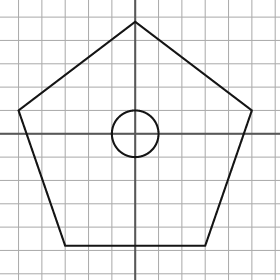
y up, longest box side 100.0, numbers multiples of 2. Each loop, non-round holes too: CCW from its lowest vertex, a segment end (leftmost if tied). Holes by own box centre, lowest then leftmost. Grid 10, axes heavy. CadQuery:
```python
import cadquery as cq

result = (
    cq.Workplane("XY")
    .moveTo(-30.0, -48.0)
    .lineTo(30.0, -48.0)
    .lineTo(50.0, 10.0)
    .lineTo(0.0, 48.0)
    .lineTo(-50.0, 10.0)
    .close()
    .moveTo(0.0, 0.0)
    .circle(10.0)
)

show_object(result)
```